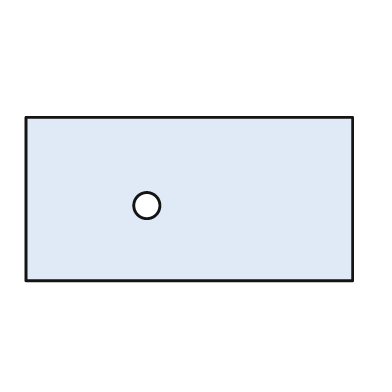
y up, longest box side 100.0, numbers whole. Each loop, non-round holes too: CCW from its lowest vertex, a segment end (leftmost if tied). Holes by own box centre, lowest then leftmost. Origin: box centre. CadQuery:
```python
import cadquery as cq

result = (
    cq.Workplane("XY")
    .moveTo(-50.0, -25.0)
    .lineTo(50.0, -25.0)
    .lineTo(50.0, 25.0)
    .lineTo(-50.0, 25.0)
    .close()
    .moveTo(-13.0, -2.0)
    .circle(4.0)
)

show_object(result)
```